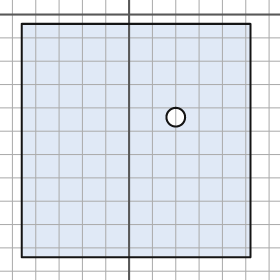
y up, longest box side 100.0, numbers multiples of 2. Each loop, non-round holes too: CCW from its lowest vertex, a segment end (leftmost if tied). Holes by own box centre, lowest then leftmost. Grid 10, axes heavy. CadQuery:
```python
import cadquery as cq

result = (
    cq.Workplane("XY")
    .moveTo(-46.0, -104.0)
    .lineTo(52.0, -104.0)
    .lineTo(52.0, -4.0)
    .lineTo(-46.0, -4.0)
    .close()
    .moveTo(20.0, -44.0)
    .circle(4.0)
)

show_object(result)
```